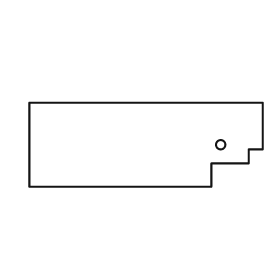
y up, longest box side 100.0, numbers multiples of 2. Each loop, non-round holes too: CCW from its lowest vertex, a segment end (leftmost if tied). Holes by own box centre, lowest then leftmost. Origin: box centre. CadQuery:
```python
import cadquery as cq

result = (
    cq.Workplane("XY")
    .moveTo(-50.0, -18.0)
    .lineTo(28.0, -18.0)
    .lineTo(28.0, -8.0)
    .lineTo(44.0, -8.0)
    .lineTo(44.0, -2.0)
    .lineTo(50.0, -2.0)
    .lineTo(50.0, 18.0)
    .lineTo(-50.0, 18.0)
    .close()
    .moveTo(32.0, 0.0)
    .circle(2.0)
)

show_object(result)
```